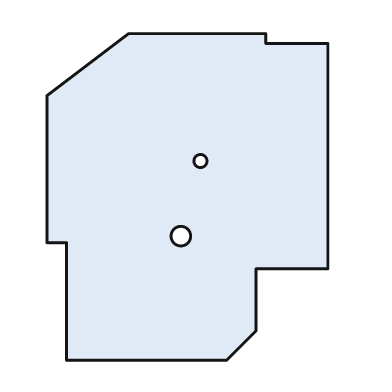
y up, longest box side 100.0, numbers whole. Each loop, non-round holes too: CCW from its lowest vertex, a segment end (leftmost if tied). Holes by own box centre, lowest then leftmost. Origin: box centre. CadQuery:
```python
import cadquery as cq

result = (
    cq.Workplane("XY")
    .moveTo(-37.0, -50.0)
    .lineTo(12.0, -50.0)
    .lineTo(21.0, -41.0)
    .lineTo(21.0, -22.0)
    .lineTo(43.0, -22.0)
    .lineTo(43.0, 47.0)
    .lineTo(24.0, 47.0)
    .lineTo(24.0, 50.0)
    .lineTo(-18.0, 50.0)
    .lineTo(-43.0, 31.0)
    .lineTo(-43.0, -14.0)
    .lineTo(-37.0, -14.0)
    .close()
    .moveTo(-2.0, -12.0)
    .circle(3.0)
    .moveTo(4.0, 11.0)
    .circle(2.0)
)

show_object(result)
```